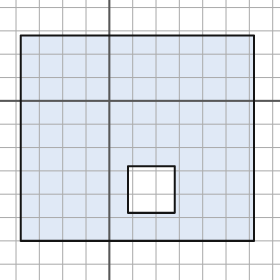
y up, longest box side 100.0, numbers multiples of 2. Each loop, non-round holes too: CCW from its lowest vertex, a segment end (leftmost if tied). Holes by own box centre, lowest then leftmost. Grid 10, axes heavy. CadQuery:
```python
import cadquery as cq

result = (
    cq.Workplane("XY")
    .moveTo(-38.0, -60.0)
    .lineTo(62.0, -60.0)
    .lineTo(62.0, 28.0)
    .lineTo(-38.0, 28.0)
    .close()
    .moveTo(8.0, -48.0)
    .lineTo(28.0, -48.0)
    .lineTo(28.0, -28.0)
    .lineTo(8.0, -28.0)
    .close()
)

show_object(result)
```